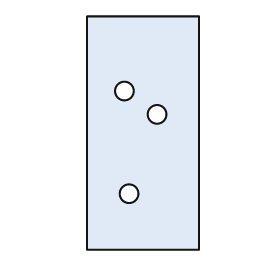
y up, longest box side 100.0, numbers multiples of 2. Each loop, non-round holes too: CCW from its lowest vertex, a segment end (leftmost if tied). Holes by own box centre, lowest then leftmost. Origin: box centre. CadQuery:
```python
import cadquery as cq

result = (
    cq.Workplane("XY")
    .moveTo(-24.0, -50.0)
    .lineTo(24.0, -50.0)
    .lineTo(24.0, 50.0)
    .lineTo(-24.0, 50.0)
    .close()
    .moveTo(-6.0, -26.0)
    .circle(4.0)
    .moveTo(6.0, 8.0)
    .circle(4.0)
    .moveTo(-8.0, 18.0)
    .circle(4.0)
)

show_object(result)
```